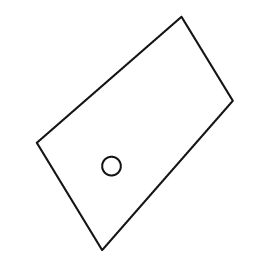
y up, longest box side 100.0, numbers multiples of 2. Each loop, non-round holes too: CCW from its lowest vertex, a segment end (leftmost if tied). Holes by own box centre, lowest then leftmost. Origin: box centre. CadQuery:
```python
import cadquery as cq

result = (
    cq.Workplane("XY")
    .moveTo(-14.0, -50.0)
    .lineTo(42.0, 14.0)
    .lineTo(20.0, 50.0)
    .lineTo(-42.0, -4.0)
    .close()
    .moveTo(-10.0, -14.0)
    .circle(4.0)
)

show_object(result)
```